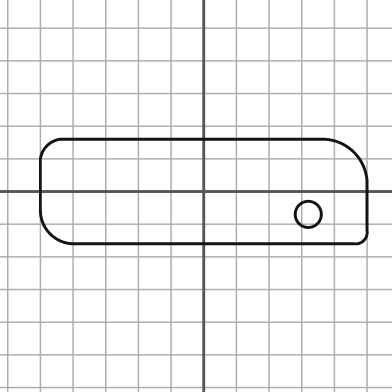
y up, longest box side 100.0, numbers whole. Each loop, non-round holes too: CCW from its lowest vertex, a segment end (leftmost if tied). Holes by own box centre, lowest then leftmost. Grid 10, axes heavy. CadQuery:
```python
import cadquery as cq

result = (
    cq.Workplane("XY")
    .moveTo(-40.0, -16.0)
    .lineTo(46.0, -16.0)
    .threePointArc((49.0, -15.0), (50.0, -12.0))
    .lineTo(50.0, 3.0)
    .threePointArc((46.0, 12.0), (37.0, 16.0))
    .lineTo(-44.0, 16.0)
    .threePointArc((-48.0, 14.0), (-50.0, 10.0))
    .lineTo(-50.0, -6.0)
    .threePointArc((-47.0, -13.0), (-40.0, -16.0))
    .close()
    .moveTo(32.0, -7.0)
    .circle(4.0)
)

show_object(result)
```